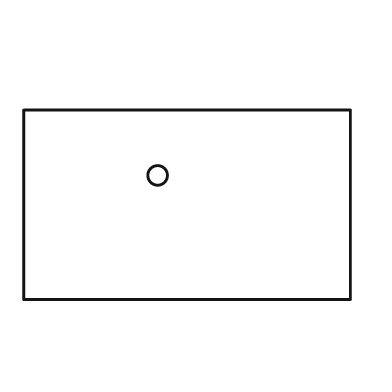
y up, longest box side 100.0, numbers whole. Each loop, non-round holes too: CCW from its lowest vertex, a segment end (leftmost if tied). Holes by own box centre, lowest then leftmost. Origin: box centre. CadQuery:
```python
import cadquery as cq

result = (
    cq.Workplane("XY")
    .moveTo(-50.0, -29.0)
    .lineTo(50.0, -29.0)
    .lineTo(50.0, 29.0)
    .lineTo(-50.0, 29.0)
    .close()
    .moveTo(-9.0, 9.0)
    .circle(3.0)
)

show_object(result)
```